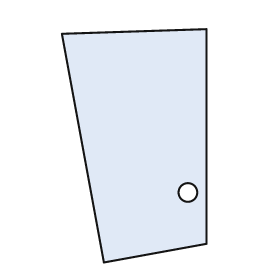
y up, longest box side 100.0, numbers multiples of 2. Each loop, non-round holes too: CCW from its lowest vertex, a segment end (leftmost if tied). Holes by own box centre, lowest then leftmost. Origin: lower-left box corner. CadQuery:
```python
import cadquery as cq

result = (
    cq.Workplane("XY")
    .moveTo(18.0, 0.0)
    .lineTo(62.0, 8.0)
    .lineTo(62.0, 100.0)
    .lineTo(0.0, 98.0)
    .close()
    .moveTo(54.0, 30.0)
    .circle(4.0)
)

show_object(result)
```